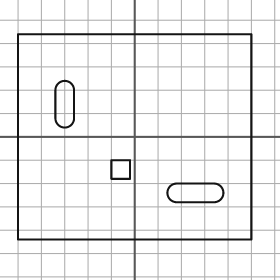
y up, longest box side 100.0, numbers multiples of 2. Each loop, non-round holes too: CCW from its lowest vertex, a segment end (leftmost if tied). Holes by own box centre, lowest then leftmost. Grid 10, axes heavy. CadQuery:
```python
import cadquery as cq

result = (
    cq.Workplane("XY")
    .moveTo(-50.0, -44.0)
    .lineTo(50.0, -44.0)
    .lineTo(50.0, 44.0)
    .lineTo(-50.0, 44.0)
    .close()
    .moveTo(18.0, -28.0)
    .lineTo(34.0, -28.0)
    .threePointArc((38.0, -24.0), (34.0, -20.0))
    .lineTo(18.0, -20.0)
    .threePointArc((14.0, -24.0), (18.0, -28.0))
    .close()
    .moveTo(-10.0, -18.0)
    .lineTo(-2.0, -18.0)
    .lineTo(-2.0, -10.0)
    .lineTo(-10.0, -10.0)
    .close()
    .moveTo(-34.0, 8.0)
    .threePointArc((-30.0, 4.0), (-26.0, 8.0))
    .lineTo(-26.0, 20.0)
    .threePointArc((-30.0, 24.0), (-34.0, 20.0))
    .close()
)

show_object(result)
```